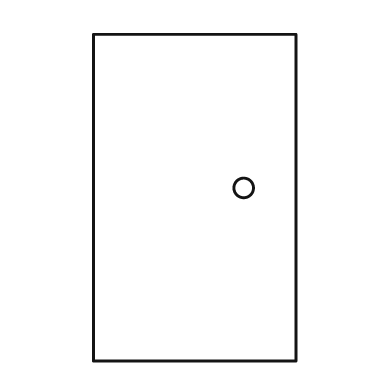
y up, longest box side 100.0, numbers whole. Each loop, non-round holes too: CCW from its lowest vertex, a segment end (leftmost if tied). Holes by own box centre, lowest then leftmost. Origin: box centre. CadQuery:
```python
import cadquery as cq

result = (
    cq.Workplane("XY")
    .moveTo(-31.0, -50.0)
    .lineTo(31.0, -50.0)
    .lineTo(31.0, 50.0)
    .lineTo(-31.0, 50.0)
    .close()
    .moveTo(15.0, 3.0)
    .circle(3.0)
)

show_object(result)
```